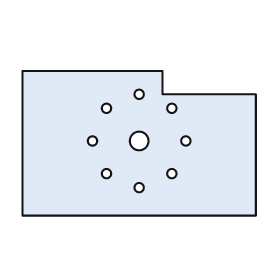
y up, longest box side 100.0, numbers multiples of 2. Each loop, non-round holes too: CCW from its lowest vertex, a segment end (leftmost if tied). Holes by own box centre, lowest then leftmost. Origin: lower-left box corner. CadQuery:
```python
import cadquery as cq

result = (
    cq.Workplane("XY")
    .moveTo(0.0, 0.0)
    .lineTo(100.0, 0.0)
    .lineTo(100.0, 52.0)
    .lineTo(60.0, 52.0)
    .lineTo(60.0, 62.0)
    .lineTo(0.0, 62.0)
    .close()
    .moveTo(50.0, 12.0)
    .circle(2.0)
    .moveTo(36.0, 18.0)
    .circle(2.0)
    .moveTo(64.0, 18.0)
    .circle(2.0)
    .moveTo(30.0, 32.0)
    .circle(2.0)
    .moveTo(50.0, 32.0)
    .circle(4.0)
    .moveTo(70.0, 32.0)
    .circle(2.0)
    .moveTo(36.0, 46.0)
    .circle(2.0)
    .moveTo(64.0, 46.0)
    .circle(2.0)
    .moveTo(50.0, 52.0)
    .circle(2.0)
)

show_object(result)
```